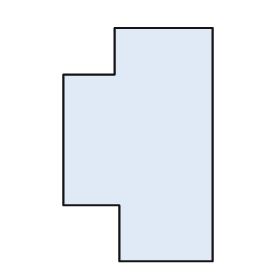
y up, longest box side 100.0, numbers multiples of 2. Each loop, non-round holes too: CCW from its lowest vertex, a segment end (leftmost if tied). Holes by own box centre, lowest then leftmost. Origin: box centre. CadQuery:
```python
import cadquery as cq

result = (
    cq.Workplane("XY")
    .moveTo(-8.0, -50.0)
    .lineTo(32.0, -50.0)
    .lineTo(32.0, 50.0)
    .lineTo(-10.0, 50.0)
    .lineTo(-10.0, 30.0)
    .lineTo(-32.0, 30.0)
    .lineTo(-32.0, -26.0)
    .lineTo(-8.0, -26.0)
    .close()
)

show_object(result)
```